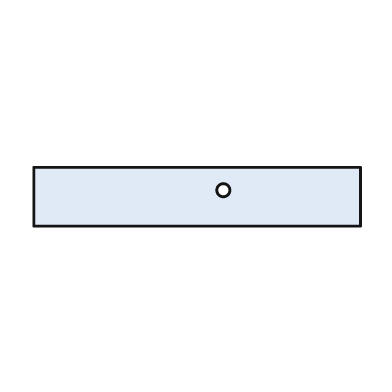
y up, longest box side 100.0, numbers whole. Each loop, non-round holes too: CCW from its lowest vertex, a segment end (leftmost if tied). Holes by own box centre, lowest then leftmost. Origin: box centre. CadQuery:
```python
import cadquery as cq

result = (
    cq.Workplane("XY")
    .moveTo(-50.0, -9.0)
    .lineTo(50.0, -9.0)
    .lineTo(50.0, 9.0)
    .lineTo(-50.0, 9.0)
    .close()
    .moveTo(8.0, 2.0)
    .circle(2.0)
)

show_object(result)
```